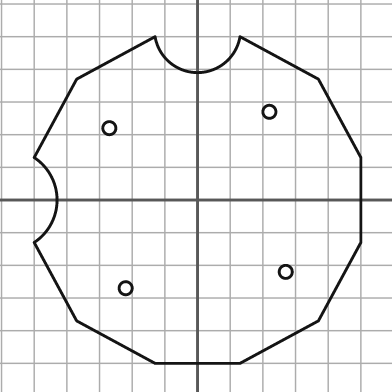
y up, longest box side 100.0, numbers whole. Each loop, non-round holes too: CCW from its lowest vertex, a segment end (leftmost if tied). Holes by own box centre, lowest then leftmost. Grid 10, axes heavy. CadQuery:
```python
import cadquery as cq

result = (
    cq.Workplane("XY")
    .moveTo(-13.0, -50.0)
    .lineTo(13.0, -50.0)
    .lineTo(37.0, -37.0)
    .lineTo(50.0, -13.0)
    .lineTo(50.0, 13.0)
    .lineTo(37.0, 37.0)
    .lineTo(13.0, 50.0)
    .threePointArc((0.0, 39.0), (-13.0, 50.0))
    .lineTo(-37.0, 37.0)
    .lineTo(-50.0, 13.0)
    .threePointArc((-43.0, 0.0), (-50.0, -13.0))
    .lineTo(-37.0, -37.0)
    .close()
    .moveTo(-22.0, -27.0)
    .circle(2.0)
    .moveTo(27.0, -22.0)
    .circle(2.0)
    .moveTo(-27.0, 22.0)
    .circle(2.0)
    .moveTo(22.0, 27.0)
    .circle(2.0)
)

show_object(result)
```